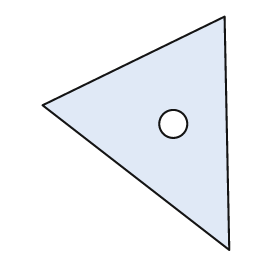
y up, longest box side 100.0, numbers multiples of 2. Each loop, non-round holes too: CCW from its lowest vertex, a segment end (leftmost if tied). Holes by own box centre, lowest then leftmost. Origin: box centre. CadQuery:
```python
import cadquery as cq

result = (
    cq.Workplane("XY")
    .moveTo(40.0, -50.0)
    .lineTo(38.0, 50.0)
    .lineTo(-40.0, 12.0)
    .close()
    .moveTo(16.0, 4.0)
    .circle(6.0)
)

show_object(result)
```